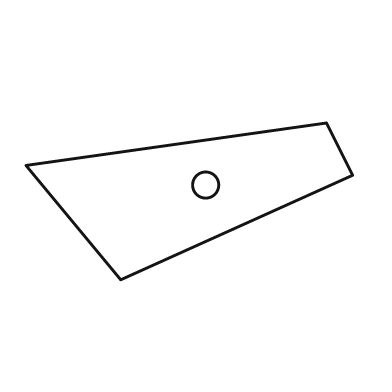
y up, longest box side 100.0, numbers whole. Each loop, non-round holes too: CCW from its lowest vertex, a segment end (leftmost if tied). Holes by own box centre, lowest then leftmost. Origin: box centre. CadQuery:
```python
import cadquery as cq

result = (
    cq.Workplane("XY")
    .moveTo(-21.0, -24.0)
    .lineTo(50.0, 8.0)
    .lineTo(42.0, 24.0)
    .lineTo(-50.0, 11.0)
    .close()
    .moveTo(5.0, 5.0)
    .circle(4.0)
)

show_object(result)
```